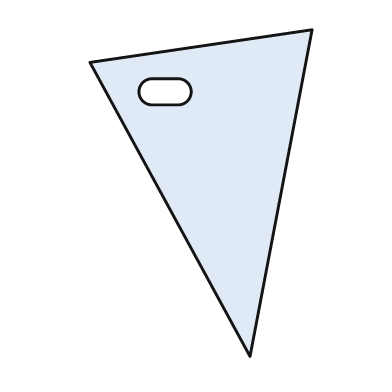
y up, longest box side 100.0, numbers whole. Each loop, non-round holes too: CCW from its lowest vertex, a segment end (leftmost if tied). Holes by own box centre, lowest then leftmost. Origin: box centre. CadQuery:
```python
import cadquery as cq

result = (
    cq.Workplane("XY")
    .moveTo(15.0, -50.0)
    .lineTo(34.0, 50.0)
    .lineTo(-34.0, 40.0)
    .close()
    .moveTo(-15.0, 27.0)
    .lineTo(-7.0, 27.0)
    .threePointArc((-3.0, 31.0), (-7.0, 35.0))
    .lineTo(-15.0, 35.0)
    .threePointArc((-19.0, 31.0), (-15.0, 27.0))
    .close()
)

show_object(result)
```